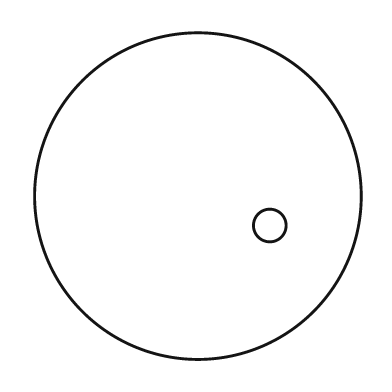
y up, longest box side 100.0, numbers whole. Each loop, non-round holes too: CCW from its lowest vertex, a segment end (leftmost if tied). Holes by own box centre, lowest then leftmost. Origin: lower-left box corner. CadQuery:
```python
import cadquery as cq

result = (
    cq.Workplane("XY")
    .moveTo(50.0, 50.0)
    .circle(50.0)
    .moveTo(72.0, 41.0)
    .circle(5.0)
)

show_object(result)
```